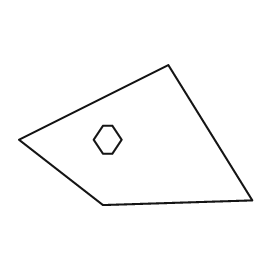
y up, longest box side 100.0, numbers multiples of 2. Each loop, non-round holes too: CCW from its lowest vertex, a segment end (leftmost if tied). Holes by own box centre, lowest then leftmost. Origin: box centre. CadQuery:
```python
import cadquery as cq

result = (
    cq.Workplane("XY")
    .moveTo(-14.0, -30.0)
    .lineTo(50.0, -28.0)
    .lineTo(14.0, 30.0)
    .lineTo(-50.0, -2.0)
    .close()
    .moveTo(-14.0, -8.0)
    .lineTo(-10.0, -8.0)
    .lineTo(-6.0, -2.0)
    .lineTo(-10.0, 4.0)
    .lineTo(-14.0, 4.0)
    .lineTo(-18.0, -2.0)
    .close()
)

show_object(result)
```